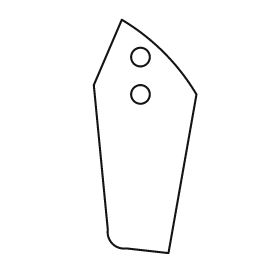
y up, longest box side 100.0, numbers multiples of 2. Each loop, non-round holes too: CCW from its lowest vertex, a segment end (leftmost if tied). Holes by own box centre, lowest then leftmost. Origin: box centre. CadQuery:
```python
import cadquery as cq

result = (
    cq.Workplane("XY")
    .moveTo(10.0, -50.0)
    .lineTo(22.0, 18.0)
    .threePointArc((8.0, 36.0), (-10.0, 50.0))
    .lineTo(-22.0, 22.0)
    .lineTo(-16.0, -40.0)
    .threePointArc((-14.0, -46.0), (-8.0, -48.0))
    .close()
    .moveTo(-2.0, 18.0)
    .circle(4.0)
    .moveTo(-2.0, 34.0)
    .circle(4.0)
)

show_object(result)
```